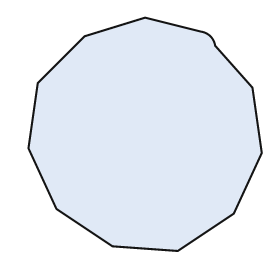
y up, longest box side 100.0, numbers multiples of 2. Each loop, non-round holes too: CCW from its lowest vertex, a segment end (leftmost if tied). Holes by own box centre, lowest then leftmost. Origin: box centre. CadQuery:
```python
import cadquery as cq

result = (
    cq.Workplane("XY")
    .moveTo(14.0, -50.0)
    .lineTo(38.0, -34.0)
    .lineTo(50.0, -8.0)
    .lineTo(46.0, 20.0)
    .lineTo(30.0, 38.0)
    .threePointArc((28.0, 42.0), (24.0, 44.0))
    .lineTo(0.0, 50.0)
    .lineTo(-26.0, 42.0)
    .lineTo(-46.0, 22.0)
    .lineTo(-50.0, -6.0)
    .lineTo(-38.0, -32.0)
    .lineTo(-14.0, -48.0)
    .close()
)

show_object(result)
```